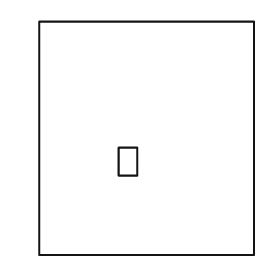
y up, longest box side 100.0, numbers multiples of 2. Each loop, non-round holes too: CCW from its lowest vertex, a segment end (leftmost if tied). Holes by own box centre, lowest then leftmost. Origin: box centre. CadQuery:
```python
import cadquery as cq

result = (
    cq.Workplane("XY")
    .moveTo(-46.0, -50.0)
    .lineTo(46.0, -50.0)
    .lineTo(46.0, 50.0)
    .lineTo(-46.0, 50.0)
    .close()
    .moveTo(-12.0, -16.0)
    .lineTo(-4.0, -16.0)
    .lineTo(-4.0, -4.0)
    .lineTo(-12.0, -4.0)
    .close()
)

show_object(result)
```